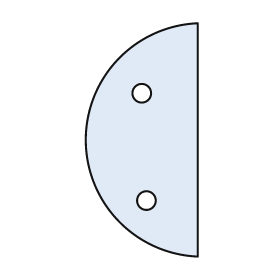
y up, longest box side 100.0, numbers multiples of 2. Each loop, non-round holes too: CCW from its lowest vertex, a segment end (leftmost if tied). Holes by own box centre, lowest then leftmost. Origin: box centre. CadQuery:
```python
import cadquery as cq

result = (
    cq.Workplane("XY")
    .moveTo(24.0, -50.0)
    .lineTo(24.0, 50.0)
    .threePointArc((-24.0, 0.0), (24.0, -50.0))
    .close()
    .moveTo(2.0, -26.0)
    .circle(4.0)
    .moveTo(0.0, 20.0)
    .circle(4.0)
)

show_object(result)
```